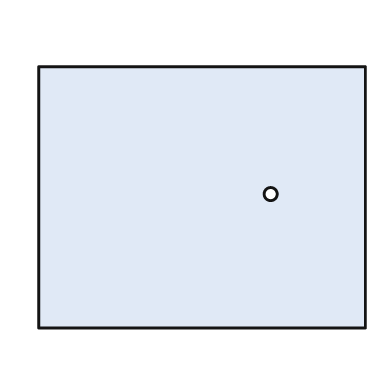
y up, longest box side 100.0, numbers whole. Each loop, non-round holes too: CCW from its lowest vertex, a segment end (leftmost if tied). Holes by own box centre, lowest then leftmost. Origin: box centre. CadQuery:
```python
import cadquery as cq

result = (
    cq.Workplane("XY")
    .moveTo(-50.0, -40.0)
    .lineTo(50.0, -40.0)
    .lineTo(50.0, 40.0)
    .lineTo(-50.0, 40.0)
    .close()
    .moveTo(21.0, 1.0)
    .circle(2.0)
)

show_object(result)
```